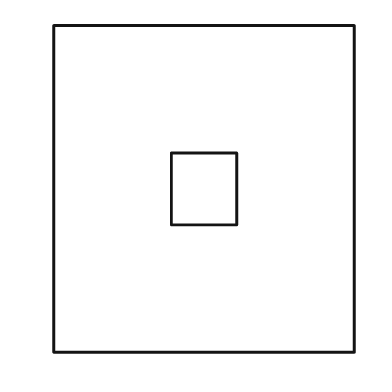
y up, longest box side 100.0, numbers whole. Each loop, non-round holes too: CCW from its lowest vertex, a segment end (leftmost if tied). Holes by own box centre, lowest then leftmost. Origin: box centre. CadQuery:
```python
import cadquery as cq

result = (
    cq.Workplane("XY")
    .moveTo(-46.0, -50.0)
    .lineTo(46.0, -50.0)
    .lineTo(46.0, 50.0)
    .lineTo(-46.0, 50.0)
    .close()
    .moveTo(-10.0, -11.0)
    .lineTo(10.0, -11.0)
    .lineTo(10.0, 11.0)
    .lineTo(-10.0, 11.0)
    .close()
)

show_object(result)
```